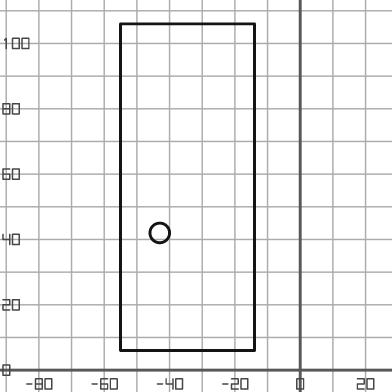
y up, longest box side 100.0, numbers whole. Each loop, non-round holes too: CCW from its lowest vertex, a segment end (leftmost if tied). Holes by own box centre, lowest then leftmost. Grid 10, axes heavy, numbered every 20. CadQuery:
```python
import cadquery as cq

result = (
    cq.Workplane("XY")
    .moveTo(-55.0, 6.0)
    .lineTo(-14.0, 6.0)
    .lineTo(-14.0, 106.0)
    .lineTo(-55.0, 106.0)
    .close()
    .moveTo(-43.0, 42.0)
    .circle(3.0)
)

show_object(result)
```